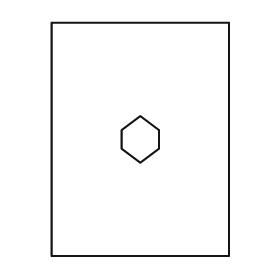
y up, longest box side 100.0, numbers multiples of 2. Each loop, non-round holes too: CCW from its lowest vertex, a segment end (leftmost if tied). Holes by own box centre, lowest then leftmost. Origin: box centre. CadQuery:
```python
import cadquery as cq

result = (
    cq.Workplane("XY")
    .moveTo(-38.0, -50.0)
    .lineTo(38.0, -50.0)
    .lineTo(38.0, 50.0)
    .lineTo(-38.0, 50.0)
    .close()
    .moveTo(0.0, -10.0)
    .lineTo(8.0, -4.0)
    .lineTo(8.0, 4.0)
    .lineTo(0.0, 10.0)
    .lineTo(-8.0, 4.0)
    .lineTo(-8.0, -4.0)
    .close()
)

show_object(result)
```